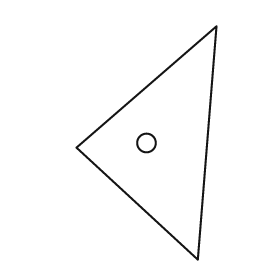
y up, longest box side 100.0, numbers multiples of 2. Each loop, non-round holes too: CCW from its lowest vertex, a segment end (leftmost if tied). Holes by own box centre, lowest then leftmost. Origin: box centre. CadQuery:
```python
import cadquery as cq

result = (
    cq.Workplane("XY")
    .moveTo(22.0, -50.0)
    .lineTo(30.0, 50.0)
    .lineTo(-30.0, -2.0)
    .close()
    .moveTo(0.0, 0.0)
    .circle(4.0)
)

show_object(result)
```